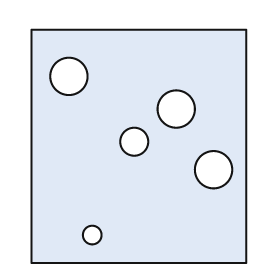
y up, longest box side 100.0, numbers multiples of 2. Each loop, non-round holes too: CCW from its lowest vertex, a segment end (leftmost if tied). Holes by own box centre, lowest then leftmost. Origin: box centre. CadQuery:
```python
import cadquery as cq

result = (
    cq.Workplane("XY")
    .moveTo(-46.0, -50.0)
    .lineTo(46.0, -50.0)
    .lineTo(46.0, 50.0)
    .lineTo(-46.0, 50.0)
    .close()
    .moveTo(-20.0, -38.0)
    .circle(4.0)
    .moveTo(32.0, -10.0)
    .circle(8.0)
    .moveTo(-2.0, 2.0)
    .circle(6.0)
    .moveTo(16.0, 16.0)
    .circle(8.0)
    .moveTo(-30.0, 30.0)
    .circle(8.0)
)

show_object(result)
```